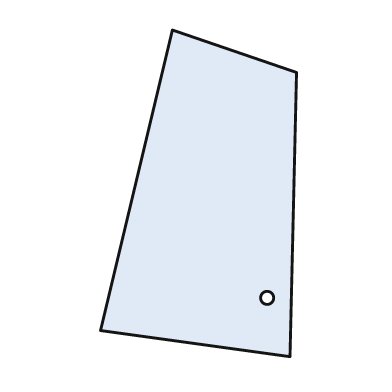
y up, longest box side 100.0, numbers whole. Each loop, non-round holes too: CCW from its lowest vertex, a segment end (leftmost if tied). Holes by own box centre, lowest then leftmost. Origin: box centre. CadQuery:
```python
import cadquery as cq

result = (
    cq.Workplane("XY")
    .moveTo(28.0, -50.0)
    .lineTo(30.0, 37.0)
    .lineTo(-8.0, 50.0)
    .lineTo(-30.0, -42.0)
    .close()
    .moveTo(21.0, -32.0)
    .circle(2.0)
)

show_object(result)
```